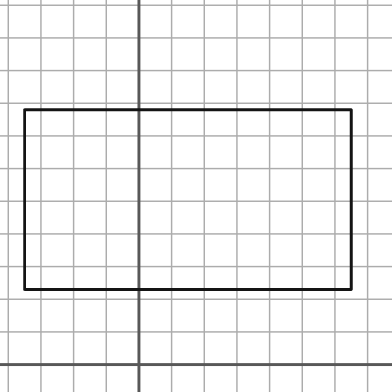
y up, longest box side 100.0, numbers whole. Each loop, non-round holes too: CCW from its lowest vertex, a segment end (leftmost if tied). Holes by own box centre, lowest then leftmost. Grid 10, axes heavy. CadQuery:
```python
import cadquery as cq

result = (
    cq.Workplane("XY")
    .moveTo(-35.0, 23.0)
    .lineTo(65.0, 23.0)
    .lineTo(65.0, 78.0)
    .lineTo(-35.0, 78.0)
    .close()
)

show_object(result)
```